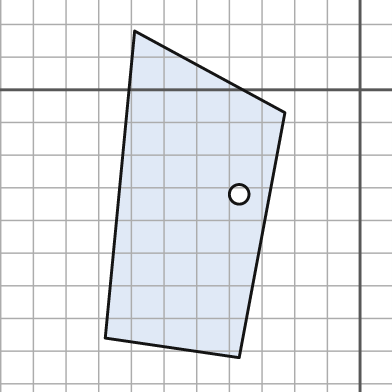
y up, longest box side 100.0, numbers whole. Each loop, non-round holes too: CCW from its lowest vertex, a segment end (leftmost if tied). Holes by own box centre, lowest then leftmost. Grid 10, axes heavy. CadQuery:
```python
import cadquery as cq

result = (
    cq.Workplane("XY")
    .moveTo(-37.0, -82.0)
    .lineTo(-23.0, -7.0)
    .lineTo(-69.0, 18.0)
    .lineTo(-78.0, -76.0)
    .close()
    .moveTo(-37.0, -32.0)
    .circle(3.0)
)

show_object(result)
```